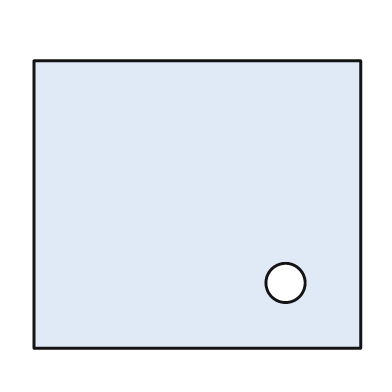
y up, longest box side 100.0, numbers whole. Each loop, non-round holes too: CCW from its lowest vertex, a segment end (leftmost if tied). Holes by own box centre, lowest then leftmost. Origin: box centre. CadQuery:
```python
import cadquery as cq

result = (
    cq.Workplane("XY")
    .moveTo(-50.0, -44.0)
    .lineTo(50.0, -44.0)
    .lineTo(50.0, 44.0)
    .lineTo(-50.0, 44.0)
    .close()
    .moveTo(27.0, -24.0)
    .circle(6.0)
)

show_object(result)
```